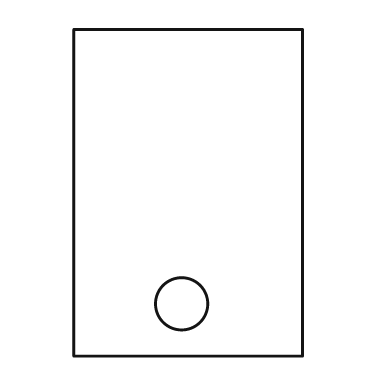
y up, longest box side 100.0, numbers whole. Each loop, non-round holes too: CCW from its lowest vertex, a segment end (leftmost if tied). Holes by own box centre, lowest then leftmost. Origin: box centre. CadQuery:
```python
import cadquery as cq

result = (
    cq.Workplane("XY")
    .moveTo(-35.0, -50.0)
    .lineTo(35.0, -50.0)
    .lineTo(35.0, 50.0)
    .lineTo(-35.0, 50.0)
    .close()
    .moveTo(-2.0, -34.0)
    .circle(8.0)
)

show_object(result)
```